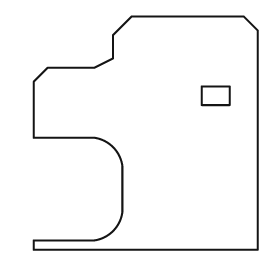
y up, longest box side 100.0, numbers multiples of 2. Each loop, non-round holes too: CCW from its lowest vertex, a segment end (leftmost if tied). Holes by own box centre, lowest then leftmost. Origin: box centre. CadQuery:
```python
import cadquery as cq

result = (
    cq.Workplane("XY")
    .moveTo(-48.0, -50.0)
    .lineTo(48.0, -50.0)
    .lineTo(48.0, 44.0)
    .lineTo(42.0, 50.0)
    .lineTo(-6.0, 50.0)
    .lineTo(-14.0, 42.0)
    .lineTo(-14.0, 32.0)
    .lineTo(-22.0, 28.0)
    .lineTo(-42.0, 28.0)
    .lineTo(-48.0, 22.0)
    .lineTo(-48.0, -2.0)
    .lineTo(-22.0, -2.0)
    .threePointArc((-14.0, -6.0), (-10.0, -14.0))
    .lineTo(-10.0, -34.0)
    .threePointArc((-14.0, -42.0), (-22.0, -46.0))
    .lineTo(-48.0, -46.0)
    .close()
    .moveTo(24.0, 12.0)
    .lineTo(36.0, 12.0)
    .lineTo(36.0, 20.0)
    .lineTo(24.0, 20.0)
    .close()
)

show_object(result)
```